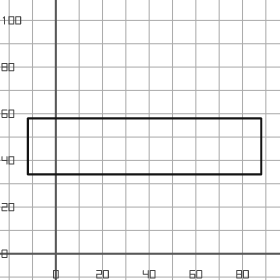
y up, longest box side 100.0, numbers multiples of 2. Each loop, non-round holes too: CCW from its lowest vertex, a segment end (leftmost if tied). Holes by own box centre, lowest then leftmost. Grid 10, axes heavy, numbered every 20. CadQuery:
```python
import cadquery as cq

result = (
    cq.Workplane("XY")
    .moveTo(-12.0, 34.0)
    .lineTo(88.0, 34.0)
    .lineTo(88.0, 58.0)
    .lineTo(-12.0, 58.0)
    .close()
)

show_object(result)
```